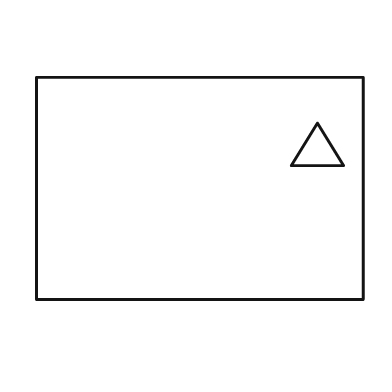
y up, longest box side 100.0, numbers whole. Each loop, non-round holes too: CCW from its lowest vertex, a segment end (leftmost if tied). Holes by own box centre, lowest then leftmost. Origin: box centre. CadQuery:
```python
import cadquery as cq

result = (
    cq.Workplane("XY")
    .moveTo(-50.0, -34.0)
    .lineTo(50.0, -34.0)
    .lineTo(50.0, 34.0)
    .lineTo(-50.0, 34.0)
    .close()
    .moveTo(28.0, 7.0)
    .lineTo(44.0, 7.0)
    .lineTo(36.0, 20.0)
    .close()
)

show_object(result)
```